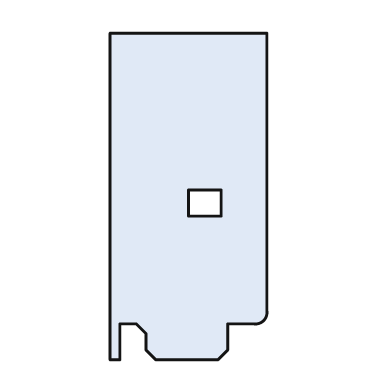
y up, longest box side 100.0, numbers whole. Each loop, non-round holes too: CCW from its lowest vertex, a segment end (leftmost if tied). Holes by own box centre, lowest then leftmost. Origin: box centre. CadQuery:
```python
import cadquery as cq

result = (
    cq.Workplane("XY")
    .moveTo(-24.0, -50.0)
    .lineTo(-21.0, -50.0)
    .lineTo(-21.0, -39.0)
    .lineTo(-16.0, -39.0)
    .lineTo(-13.0, -42.0)
    .lineTo(-13.0, -47.0)
    .lineTo(-10.0, -50.0)
    .lineTo(9.0, -50.0)
    .lineTo(12.0, -47.0)
    .lineTo(12.0, -39.0)
    .lineTo(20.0, -39.0)
    .threePointArc((23.0, -38.0), (24.0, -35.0))
    .lineTo(24.0, 50.0)
    .lineTo(-24.0, 50.0)
    .close()
    .moveTo(0.0, -6.0)
    .lineTo(10.0, -6.0)
    .lineTo(10.0, 2.0)
    .lineTo(0.0, 2.0)
    .close()
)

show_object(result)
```